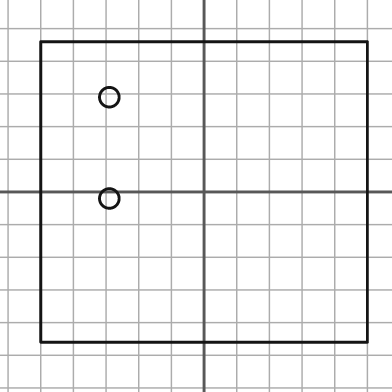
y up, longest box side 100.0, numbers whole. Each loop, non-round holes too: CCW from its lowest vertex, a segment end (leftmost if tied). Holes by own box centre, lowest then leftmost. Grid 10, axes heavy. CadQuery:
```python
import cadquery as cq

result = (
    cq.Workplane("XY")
    .moveTo(-50.0, -46.0)
    .lineTo(50.0, -46.0)
    .lineTo(50.0, 46.0)
    .lineTo(-50.0, 46.0)
    .close()
    .moveTo(-29.0, -2.0)
    .circle(3.0)
    .moveTo(-29.0, 29.0)
    .circle(3.0)
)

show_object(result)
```